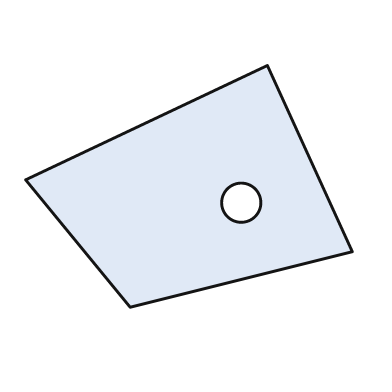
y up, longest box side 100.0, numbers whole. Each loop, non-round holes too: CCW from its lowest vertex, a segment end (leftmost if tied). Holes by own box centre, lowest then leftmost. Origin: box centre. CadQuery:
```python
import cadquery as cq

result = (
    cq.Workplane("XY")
    .moveTo(-18.0, -37.0)
    .lineTo(50.0, -20.0)
    .lineTo(24.0, 37.0)
    .lineTo(-50.0, 2.0)
    .close()
    .moveTo(16.0, -5.0)
    .circle(6.0)
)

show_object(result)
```